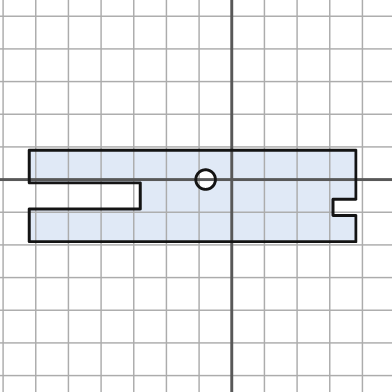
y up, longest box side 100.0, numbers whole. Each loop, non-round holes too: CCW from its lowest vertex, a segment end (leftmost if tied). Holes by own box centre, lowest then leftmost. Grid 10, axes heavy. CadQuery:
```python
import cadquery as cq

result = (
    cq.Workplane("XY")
    .moveTo(-62.0, -19.0)
    .lineTo(38.0, -19.0)
    .lineTo(38.0, -11.0)
    .lineTo(31.0, -11.0)
    .lineTo(31.0, -6.0)
    .lineTo(38.0, -6.0)
    .lineTo(38.0, 9.0)
    .lineTo(-62.0, 9.0)
    .lineTo(-62.0, -1.0)
    .lineTo(-28.0, -1.0)
    .lineTo(-28.0, -9.0)
    .lineTo(-62.0, -9.0)
    .close()
    .moveTo(-8.0, 0.0)
    .circle(3.0)
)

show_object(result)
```